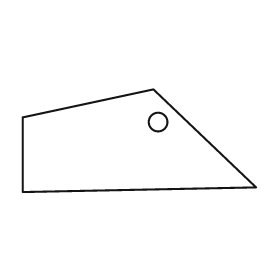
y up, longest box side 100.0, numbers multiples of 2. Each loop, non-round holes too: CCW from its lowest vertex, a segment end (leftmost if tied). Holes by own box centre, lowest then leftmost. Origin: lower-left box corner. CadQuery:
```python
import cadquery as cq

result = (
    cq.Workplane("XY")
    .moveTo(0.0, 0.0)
    .lineTo(100.0, 2.0)
    .lineTo(56.0, 44.0)
    .lineTo(0.0, 32.0)
    .close()
    .moveTo(58.0, 30.0)
    .circle(4.0)
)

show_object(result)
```